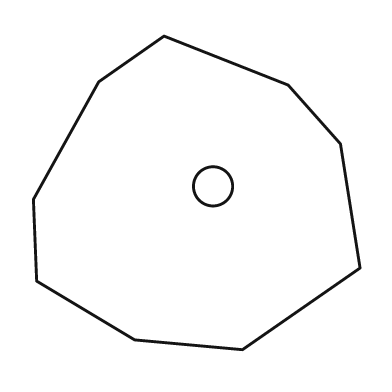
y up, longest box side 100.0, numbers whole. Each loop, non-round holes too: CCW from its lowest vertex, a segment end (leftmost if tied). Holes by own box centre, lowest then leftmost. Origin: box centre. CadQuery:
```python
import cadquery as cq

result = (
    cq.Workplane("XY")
    .moveTo(14.0, -48.0)
    .lineTo(50.0, -23.0)
    .lineTo(44.0, 15.0)
    .lineTo(28.0, 33.0)
    .lineTo(-10.0, 48.0)
    .lineTo(-30.0, 34.0)
    .lineTo(-50.0, -2.0)
    .lineTo(-49.0, -27.0)
    .lineTo(-19.0, -45.0)
    .close()
    .moveTo(5.0, 2.0)
    .circle(6.0)
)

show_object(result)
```